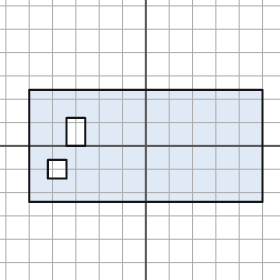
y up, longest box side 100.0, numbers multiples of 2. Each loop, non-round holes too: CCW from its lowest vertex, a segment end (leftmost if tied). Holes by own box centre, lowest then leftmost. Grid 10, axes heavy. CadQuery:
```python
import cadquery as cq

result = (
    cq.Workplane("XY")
    .moveTo(-50.0, -24.0)
    .lineTo(50.0, -24.0)
    .lineTo(50.0, 24.0)
    .lineTo(-50.0, 24.0)
    .close()
    .moveTo(-42.0, -14.0)
    .lineTo(-34.0, -14.0)
    .lineTo(-34.0, -6.0)
    .lineTo(-42.0, -6.0)
    .close()
    .moveTo(-34.0, 0.0)
    .lineTo(-26.0, 0.0)
    .lineTo(-26.0, 12.0)
    .lineTo(-34.0, 12.0)
    .close()
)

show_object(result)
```